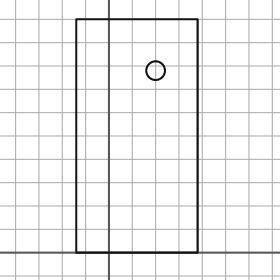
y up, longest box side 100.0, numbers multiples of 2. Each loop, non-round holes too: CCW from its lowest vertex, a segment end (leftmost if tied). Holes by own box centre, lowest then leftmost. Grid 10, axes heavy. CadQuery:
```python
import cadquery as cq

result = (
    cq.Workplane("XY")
    .moveTo(-14.0, 0.0)
    .lineTo(38.0, 0.0)
    .lineTo(38.0, 100.0)
    .lineTo(-14.0, 100.0)
    .close()
    .moveTo(20.0, 78.0)
    .circle(4.0)
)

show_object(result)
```